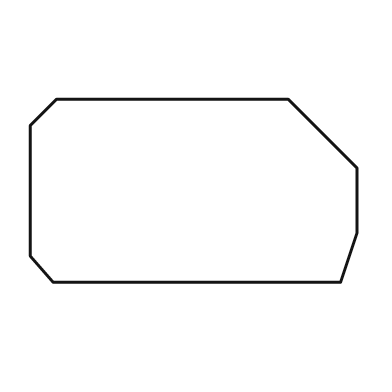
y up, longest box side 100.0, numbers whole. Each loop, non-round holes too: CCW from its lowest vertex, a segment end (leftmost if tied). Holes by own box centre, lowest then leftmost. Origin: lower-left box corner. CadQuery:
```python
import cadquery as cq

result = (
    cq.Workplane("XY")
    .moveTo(7.0, 0.0)
    .lineTo(95.0, 0.0)
    .lineTo(100.0, 15.0)
    .lineTo(100.0, 35.0)
    .lineTo(79.0, 56.0)
    .lineTo(8.0, 56.0)
    .lineTo(0.0, 48.0)
    .lineTo(0.0, 8.0)
    .close()
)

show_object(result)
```